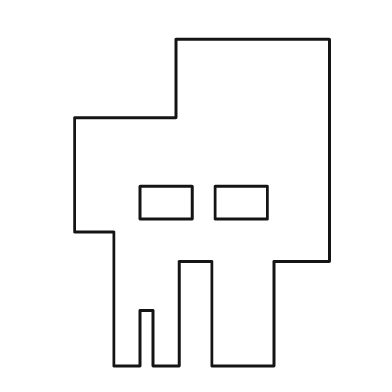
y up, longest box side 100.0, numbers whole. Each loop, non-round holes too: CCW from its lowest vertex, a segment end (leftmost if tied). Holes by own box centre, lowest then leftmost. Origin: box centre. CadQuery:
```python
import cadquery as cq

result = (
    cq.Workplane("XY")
    .moveTo(-27.0, -50.0)
    .lineTo(-19.0, -50.0)
    .lineTo(-19.0, -33.0)
    .lineTo(-15.0, -33.0)
    .lineTo(-15.0, -50.0)
    .lineTo(-7.0, -50.0)
    .lineTo(-7.0, -18.0)
    .lineTo(3.0, -18.0)
    .lineTo(3.0, -50.0)
    .lineTo(22.0, -50.0)
    .lineTo(22.0, -18.0)
    .lineTo(39.0, -18.0)
    .lineTo(39.0, 50.0)
    .lineTo(-8.0, 50.0)
    .lineTo(-8.0, 26.0)
    .lineTo(-39.0, 26.0)
    .lineTo(-39.0, -9.0)
    .lineTo(-27.0, -9.0)
    .close()
    .moveTo(-19.0, -5.0)
    .lineTo(-3.0, -5.0)
    .lineTo(-3.0, 5.0)
    .lineTo(-19.0, 5.0)
    .close()
    .moveTo(4.0, -5.0)
    .lineTo(20.0, -5.0)
    .lineTo(20.0, 5.0)
    .lineTo(4.0, 5.0)
    .close()
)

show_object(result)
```